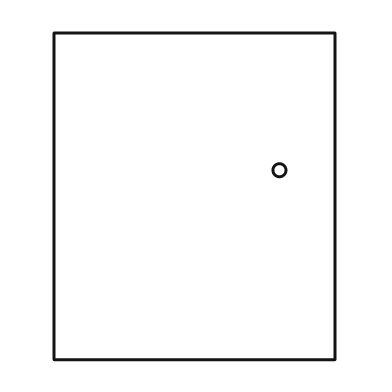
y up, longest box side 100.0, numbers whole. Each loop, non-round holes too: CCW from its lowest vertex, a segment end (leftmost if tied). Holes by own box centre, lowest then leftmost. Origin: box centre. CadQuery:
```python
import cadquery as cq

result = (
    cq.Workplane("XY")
    .moveTo(-43.0, -50.0)
    .lineTo(43.0, -50.0)
    .lineTo(43.0, 50.0)
    .lineTo(-43.0, 50.0)
    .close()
    .moveTo(26.0, 8.0)
    .circle(2.0)
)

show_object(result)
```